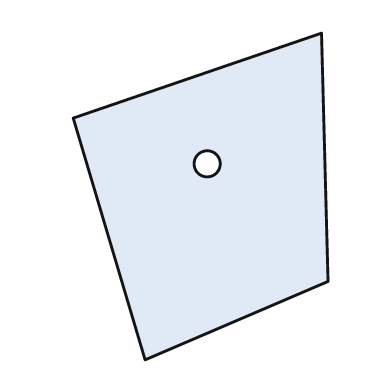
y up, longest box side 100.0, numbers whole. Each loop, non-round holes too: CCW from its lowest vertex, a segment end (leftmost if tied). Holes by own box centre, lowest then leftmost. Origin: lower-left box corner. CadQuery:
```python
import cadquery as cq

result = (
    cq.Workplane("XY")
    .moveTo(22.0, 0.0)
    .lineTo(78.0, 24.0)
    .lineTo(76.0, 100.0)
    .lineTo(0.0, 74.0)
    .close()
    .moveTo(41.0, 60.0)
    .circle(4.0)
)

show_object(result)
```